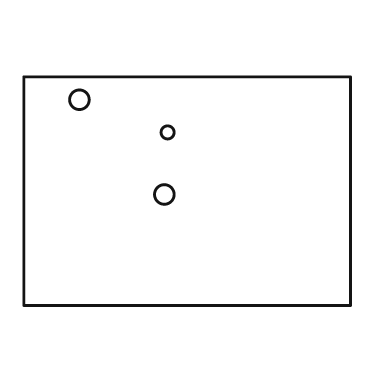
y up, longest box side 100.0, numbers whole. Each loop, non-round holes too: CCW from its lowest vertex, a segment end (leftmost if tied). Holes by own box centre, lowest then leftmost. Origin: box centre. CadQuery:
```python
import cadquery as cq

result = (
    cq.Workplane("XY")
    .moveTo(-50.0, -35.0)
    .lineTo(50.0, -35.0)
    .lineTo(50.0, 35.0)
    .lineTo(-50.0, 35.0)
    .close()
    .moveTo(-7.0, -1.0)
    .circle(3.0)
    .moveTo(-6.0, 18.0)
    .circle(2.0)
    .moveTo(-33.0, 28.0)
    .circle(3.0)
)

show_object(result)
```